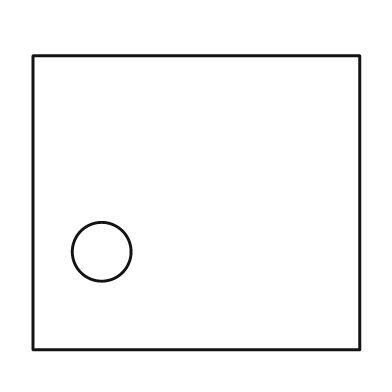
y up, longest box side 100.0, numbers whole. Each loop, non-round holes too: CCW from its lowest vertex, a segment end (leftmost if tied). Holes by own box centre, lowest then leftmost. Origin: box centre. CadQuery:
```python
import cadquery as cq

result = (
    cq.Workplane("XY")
    .moveTo(-50.0, -45.0)
    .lineTo(50.0, -45.0)
    .lineTo(50.0, 45.0)
    .lineTo(-50.0, 45.0)
    .close()
    .moveTo(-29.0, -15.0)
    .circle(9.0)
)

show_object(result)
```